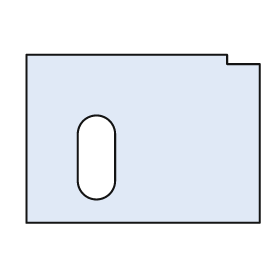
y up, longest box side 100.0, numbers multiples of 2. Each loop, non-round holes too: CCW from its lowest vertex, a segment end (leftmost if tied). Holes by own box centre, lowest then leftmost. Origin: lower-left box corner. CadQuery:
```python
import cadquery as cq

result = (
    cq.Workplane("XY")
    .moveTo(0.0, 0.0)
    .lineTo(100.0, 0.0)
    .lineTo(100.0, 68.0)
    .lineTo(86.0, 68.0)
    .lineTo(86.0, 72.0)
    .lineTo(0.0, 72.0)
    .close()
    .moveTo(22.0, 18.0)
    .threePointArc((30.0, 10.0), (38.0, 18.0))
    .lineTo(38.0, 38.0)
    .threePointArc((30.0, 46.0), (22.0, 38.0))
    .close()
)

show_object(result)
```